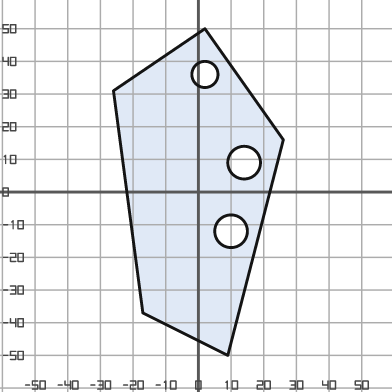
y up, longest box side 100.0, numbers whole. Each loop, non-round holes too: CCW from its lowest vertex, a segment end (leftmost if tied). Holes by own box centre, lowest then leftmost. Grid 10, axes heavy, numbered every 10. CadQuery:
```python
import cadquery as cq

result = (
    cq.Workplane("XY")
    .moveTo(9.0, -50.0)
    .lineTo(26.0, 16.0)
    .lineTo(2.0, 50.0)
    .lineTo(-26.0, 31.0)
    .lineTo(-17.0, -37.0)
    .close()
    .moveTo(10.0, -12.0)
    .circle(5.0)
    .moveTo(14.0, 9.0)
    .circle(5.0)
    .moveTo(2.0, 36.0)
    .circle(4.0)
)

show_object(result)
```